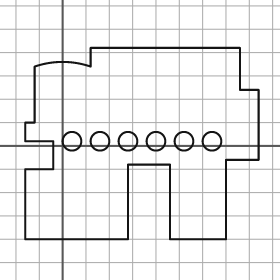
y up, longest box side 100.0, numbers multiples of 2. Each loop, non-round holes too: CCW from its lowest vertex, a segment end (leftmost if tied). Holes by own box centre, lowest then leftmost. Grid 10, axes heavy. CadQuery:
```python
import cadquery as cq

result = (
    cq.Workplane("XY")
    .moveTo(-16.0, -40.0)
    .lineTo(28.0, -40.0)
    .lineTo(28.0, -8.0)
    .lineTo(46.0, -8.0)
    .lineTo(46.0, -40.0)
    .lineTo(70.0, -40.0)
    .lineTo(70.0, -6.0)
    .lineTo(84.0, -6.0)
    .lineTo(84.0, 24.0)
    .lineTo(76.0, 24.0)
    .lineTo(76.0, 42.0)
    .lineTo(12.0, 42.0)
    .lineTo(12.0, 34.0)
    .threePointArc((0.0, 36.0), (-12.0, 34.0))
    .lineTo(-12.0, 10.0)
    .lineTo(-16.0, 10.0)
    .lineTo(-16.0, 2.0)
    .lineTo(-4.0, 2.0)
    .lineTo(-4.0, -10.0)
    .lineTo(-16.0, -10.0)
    .close()
    .moveTo(4.0, 2.0)
    .circle(4.0)
    .moveTo(16.0, 2.0)
    .circle(4.0)
    .moveTo(28.0, 2.0)
    .circle(4.0)
    .moveTo(40.0, 2.0)
    .circle(4.0)
    .moveTo(52.0, 2.0)
    .circle(4.0)
    .moveTo(64.0, 2.0)
    .circle(4.0)
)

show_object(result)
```